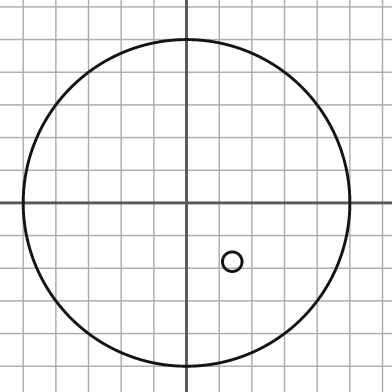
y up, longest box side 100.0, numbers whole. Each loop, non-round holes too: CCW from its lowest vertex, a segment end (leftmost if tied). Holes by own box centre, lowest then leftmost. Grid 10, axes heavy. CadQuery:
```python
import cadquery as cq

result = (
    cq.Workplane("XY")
    .moveTo(0.0, 0.0)
    .circle(50.0)
    .moveTo(14.0, -18.0)
    .circle(3.0)
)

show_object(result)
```